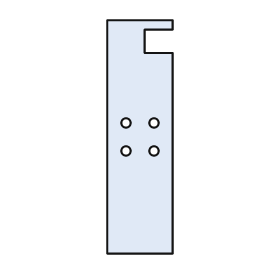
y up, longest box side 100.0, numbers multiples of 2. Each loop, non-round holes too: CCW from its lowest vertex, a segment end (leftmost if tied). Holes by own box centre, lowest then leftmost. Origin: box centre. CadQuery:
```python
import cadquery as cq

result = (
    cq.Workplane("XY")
    .moveTo(-14.0, -50.0)
    .lineTo(14.0, -50.0)
    .lineTo(14.0, 36.0)
    .lineTo(2.0, 36.0)
    .lineTo(2.0, 46.0)
    .lineTo(14.0, 46.0)
    .lineTo(14.0, 50.0)
    .lineTo(-14.0, 50.0)
    .close()
    .moveTo(-6.0, -6.0)
    .circle(2.0)
    .moveTo(6.0, -6.0)
    .circle(2.0)
    .moveTo(-6.0, 6.0)
    .circle(2.0)
    .moveTo(6.0, 6.0)
    .circle(2.0)
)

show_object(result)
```